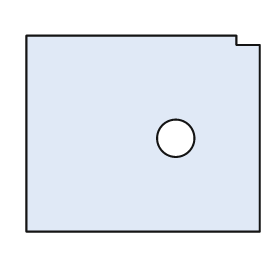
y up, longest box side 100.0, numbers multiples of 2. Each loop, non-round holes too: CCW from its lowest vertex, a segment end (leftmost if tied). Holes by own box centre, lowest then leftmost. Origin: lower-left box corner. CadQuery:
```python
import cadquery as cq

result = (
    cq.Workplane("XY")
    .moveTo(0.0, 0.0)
    .lineTo(100.0, 0.0)
    .lineTo(100.0, 80.0)
    .lineTo(90.0, 80.0)
    .lineTo(90.0, 84.0)
    .lineTo(0.0, 84.0)
    .close()
    .moveTo(64.0, 40.0)
    .circle(8.0)
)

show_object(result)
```